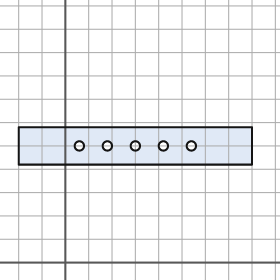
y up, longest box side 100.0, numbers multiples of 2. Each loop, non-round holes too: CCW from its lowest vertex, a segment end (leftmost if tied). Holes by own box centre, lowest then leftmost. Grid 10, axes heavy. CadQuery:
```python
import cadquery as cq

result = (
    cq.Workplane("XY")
    .moveTo(-20.0, 42.0)
    .lineTo(80.0, 42.0)
    .lineTo(80.0, 58.0)
    .lineTo(-20.0, 58.0)
    .close()
    .moveTo(6.0, 50.0)
    .circle(2.0)
    .moveTo(18.0, 50.0)
    .circle(2.0)
    .moveTo(30.0, 50.0)
    .circle(2.0)
    .moveTo(42.0, 50.0)
    .circle(2.0)
    .moveTo(54.0, 50.0)
    .circle(2.0)
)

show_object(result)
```